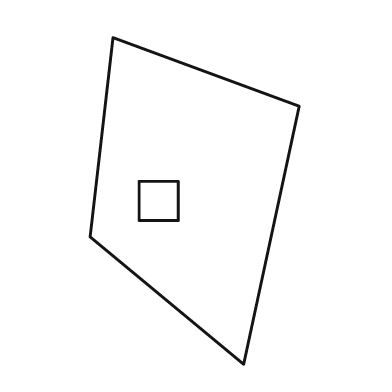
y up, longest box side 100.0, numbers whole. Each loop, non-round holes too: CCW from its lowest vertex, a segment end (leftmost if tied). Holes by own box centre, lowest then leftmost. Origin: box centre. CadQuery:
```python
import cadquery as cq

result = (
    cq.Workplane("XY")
    .moveTo(15.0, -50.0)
    .lineTo(32.0, 29.0)
    .lineTo(-25.0, 50.0)
    .lineTo(-32.0, -11.0)
    .close()
    .moveTo(-17.0, -6.0)
    .lineTo(-5.0, -6.0)
    .lineTo(-5.0, 6.0)
    .lineTo(-17.0, 6.0)
    .close()
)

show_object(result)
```